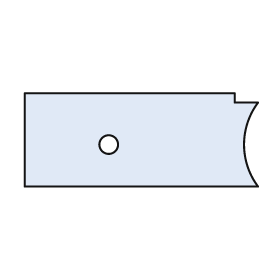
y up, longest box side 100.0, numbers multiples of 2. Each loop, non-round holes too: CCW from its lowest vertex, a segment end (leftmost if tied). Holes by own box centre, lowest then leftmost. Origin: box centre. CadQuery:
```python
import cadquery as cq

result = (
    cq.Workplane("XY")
    .moveTo(-50.0, -20.0)
    .lineTo(50.0, -20.0)
    .threePointArc((44.0, -2.0), (50.0, 16.0))
    .lineTo(40.0, 16.0)
    .lineTo(40.0, 20.0)
    .lineTo(-50.0, 20.0)
    .close()
    .moveTo(-14.0, -2.0)
    .circle(4.0)
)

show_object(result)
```